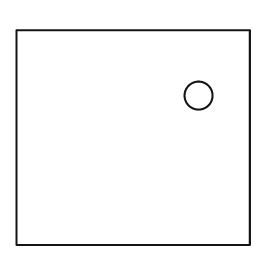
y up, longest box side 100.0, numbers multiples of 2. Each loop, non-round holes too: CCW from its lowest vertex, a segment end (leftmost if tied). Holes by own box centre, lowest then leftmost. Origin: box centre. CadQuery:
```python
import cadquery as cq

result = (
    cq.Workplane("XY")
    .moveTo(-50.0, -46.0)
    .lineTo(50.0, -46.0)
    .lineTo(50.0, 46.0)
    .lineTo(-50.0, 46.0)
    .close()
    .moveTo(28.0, 18.0)
    .circle(6.0)
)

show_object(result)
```